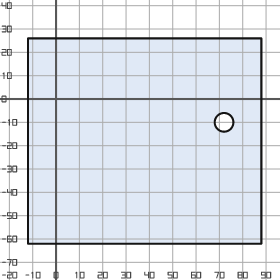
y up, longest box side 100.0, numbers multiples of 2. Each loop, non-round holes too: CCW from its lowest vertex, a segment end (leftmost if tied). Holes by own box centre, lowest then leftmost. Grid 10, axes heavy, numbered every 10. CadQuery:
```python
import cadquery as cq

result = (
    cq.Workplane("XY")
    .moveTo(-12.0, -62.0)
    .lineTo(88.0, -62.0)
    .lineTo(88.0, 26.0)
    .lineTo(-12.0, 26.0)
    .close()
    .moveTo(72.0, -10.0)
    .circle(4.0)
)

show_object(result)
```